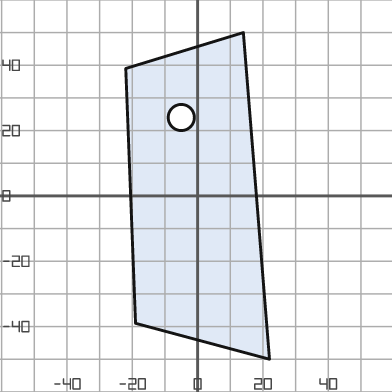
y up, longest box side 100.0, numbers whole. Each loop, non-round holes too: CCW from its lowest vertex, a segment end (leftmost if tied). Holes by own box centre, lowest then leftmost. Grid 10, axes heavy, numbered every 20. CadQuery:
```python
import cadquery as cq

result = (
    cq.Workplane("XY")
    .moveTo(22.0, -50.0)
    .lineTo(14.0, 50.0)
    .lineTo(-22.0, 39.0)
    .lineTo(-19.0, -39.0)
    .close()
    .moveTo(-5.0, 24.0)
    .circle(4.0)
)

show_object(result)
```